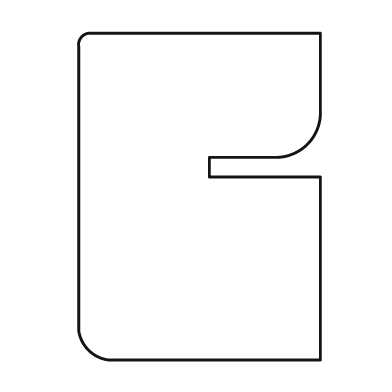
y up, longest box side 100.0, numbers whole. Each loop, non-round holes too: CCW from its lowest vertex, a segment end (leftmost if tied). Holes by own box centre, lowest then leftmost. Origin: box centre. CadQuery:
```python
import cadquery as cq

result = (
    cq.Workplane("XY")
    .moveTo(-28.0, -50.0)
    .lineTo(37.0, -50.0)
    .lineTo(37.0, 6.0)
    .lineTo(3.0, 6.0)
    .lineTo(3.0, 12.0)
    .lineTo(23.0, 12.0)
    .threePointArc((33.0, 16.0), (37.0, 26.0))
    .lineTo(37.0, 50.0)
    .lineTo(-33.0, 50.0)
    .threePointArc((-36.0, 49.0), (-37.0, 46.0))
    .lineTo(-37.0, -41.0)
    .threePointArc((-34.0, -47.0), (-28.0, -50.0))
    .close()
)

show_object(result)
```